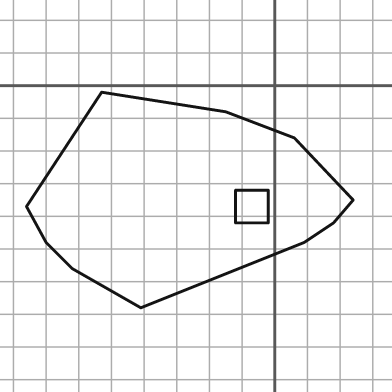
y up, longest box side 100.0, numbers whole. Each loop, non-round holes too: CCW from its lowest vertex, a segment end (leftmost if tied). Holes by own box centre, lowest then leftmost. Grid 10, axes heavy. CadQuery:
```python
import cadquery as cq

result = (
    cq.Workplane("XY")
    .moveTo(-41.0, -68.0)
    .lineTo(9.0, -48.0)
    .lineTo(18.0, -42.0)
    .lineTo(24.0, -35.0)
    .lineTo(6.0, -16.0)
    .lineTo(-15.0, -8.0)
    .lineTo(-53.0, -2.0)
    .lineTo(-76.0, -37.0)
    .lineTo(-70.0, -48.0)
    .lineTo(-62.0, -56.0)
    .close()
    .moveTo(-12.0, -42.0)
    .lineTo(-2.0, -42.0)
    .lineTo(-2.0, -32.0)
    .lineTo(-12.0, -32.0)
    .close()
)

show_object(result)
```